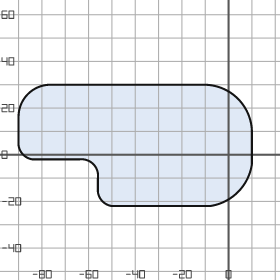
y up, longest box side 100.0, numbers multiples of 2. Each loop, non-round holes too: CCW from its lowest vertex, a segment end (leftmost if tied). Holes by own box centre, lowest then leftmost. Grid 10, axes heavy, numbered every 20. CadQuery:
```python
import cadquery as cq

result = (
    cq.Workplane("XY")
    .moveTo(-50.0, -22.0)
    .lineTo(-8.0, -22.0)
    .threePointArc((4.0, -16.0), (10.0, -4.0))
    .lineTo(10.0, 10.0)
    .threePointArc((4.0, 24.0), (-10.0, 30.0))
    .lineTo(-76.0, 30.0)
    .threePointArc((-86.0, 26.0), (-90.0, 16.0))
    .lineTo(-90.0, 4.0)
    .threePointArc((-88.0, 0.0), (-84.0, -2.0))
    .lineTo(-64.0, -2.0)
    .threePointArc((-58.0, -4.0), (-56.0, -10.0))
    .lineTo(-56.0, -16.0)
    .threePointArc((-54.0, -20.0), (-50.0, -22.0))
    .close()
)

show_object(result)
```